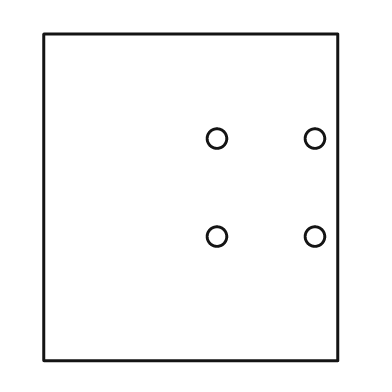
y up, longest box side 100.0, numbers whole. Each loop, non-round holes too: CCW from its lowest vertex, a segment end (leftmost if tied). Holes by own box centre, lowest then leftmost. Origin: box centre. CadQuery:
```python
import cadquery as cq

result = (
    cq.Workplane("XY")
    .moveTo(-45.0, -50.0)
    .lineTo(45.0, -50.0)
    .lineTo(45.0, 50.0)
    .lineTo(-45.0, 50.0)
    .close()
    .moveTo(8.0, -12.0)
    .circle(3.0)
    .moveTo(38.0, -12.0)
    .circle(3.0)
    .moveTo(8.0, 18.0)
    .circle(3.0)
    .moveTo(38.0, 18.0)
    .circle(3.0)
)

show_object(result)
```